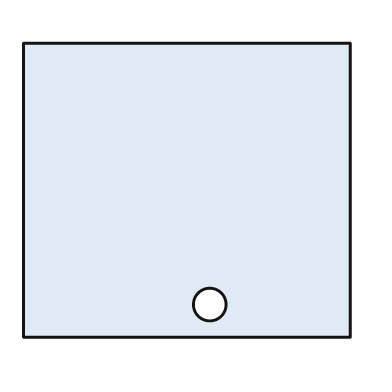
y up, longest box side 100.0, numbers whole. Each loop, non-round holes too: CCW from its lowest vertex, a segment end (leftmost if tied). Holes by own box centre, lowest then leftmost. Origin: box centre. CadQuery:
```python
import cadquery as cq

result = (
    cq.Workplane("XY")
    .moveTo(-50.0, -45.0)
    .lineTo(50.0, -45.0)
    .lineTo(50.0, 45.0)
    .lineTo(-50.0, 45.0)
    .close()
    .moveTo(7.0, -35.0)
    .circle(5.0)
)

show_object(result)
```